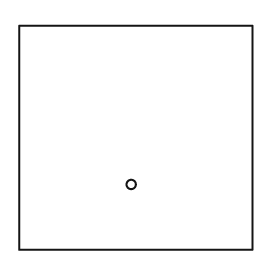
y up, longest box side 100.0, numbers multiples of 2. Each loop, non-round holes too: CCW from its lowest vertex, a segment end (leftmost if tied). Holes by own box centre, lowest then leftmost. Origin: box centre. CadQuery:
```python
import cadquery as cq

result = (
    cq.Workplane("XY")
    .moveTo(-50.0, -48.0)
    .lineTo(50.0, -48.0)
    .lineTo(50.0, 48.0)
    .lineTo(-50.0, 48.0)
    .close()
    .moveTo(-2.0, -20.0)
    .circle(2.0)
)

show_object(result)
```